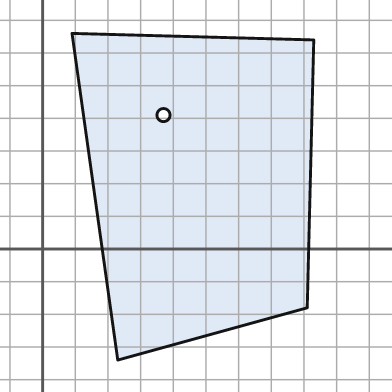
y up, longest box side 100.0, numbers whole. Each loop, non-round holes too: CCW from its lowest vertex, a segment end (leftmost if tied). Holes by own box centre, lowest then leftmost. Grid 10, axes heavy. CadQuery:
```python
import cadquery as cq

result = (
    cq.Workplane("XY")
    .moveTo(23.0, -34.0)
    .lineTo(81.0, -18.0)
    .lineTo(83.0, 64.0)
    .lineTo(9.0, 66.0)
    .close()
    .moveTo(37.0, 41.0)
    .circle(2.0)
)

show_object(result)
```